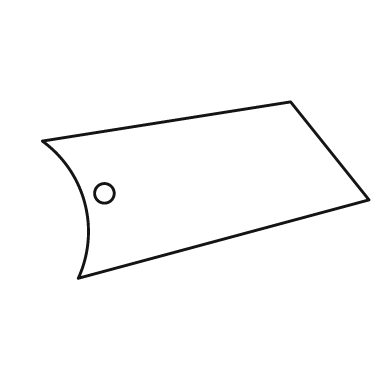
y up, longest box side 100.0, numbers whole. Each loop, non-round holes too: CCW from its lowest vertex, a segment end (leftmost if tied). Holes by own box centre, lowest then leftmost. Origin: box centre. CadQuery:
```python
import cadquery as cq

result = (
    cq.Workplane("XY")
    .moveTo(-39.0, -27.0)
    .lineTo(50.0, -3.0)
    .lineTo(26.0, 27.0)
    .lineTo(-50.0, 15.0)
    .threePointArc((-37.0, -4.0), (-39.0, -27.0))
    .close()
    .moveTo(-31.0, -1.0)
    .circle(3.0)
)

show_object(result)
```